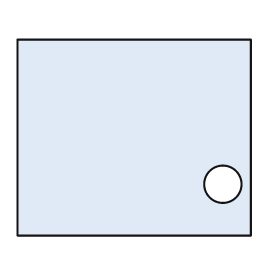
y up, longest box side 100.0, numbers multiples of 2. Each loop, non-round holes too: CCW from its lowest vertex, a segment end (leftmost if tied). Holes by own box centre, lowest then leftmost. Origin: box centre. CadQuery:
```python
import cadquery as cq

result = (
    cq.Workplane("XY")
    .moveTo(-50.0, -42.0)
    .lineTo(50.0, -42.0)
    .lineTo(50.0, 42.0)
    .lineTo(-50.0, 42.0)
    .close()
    .moveTo(38.0, -20.0)
    .circle(8.0)
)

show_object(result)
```